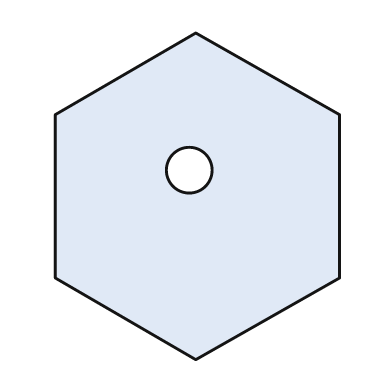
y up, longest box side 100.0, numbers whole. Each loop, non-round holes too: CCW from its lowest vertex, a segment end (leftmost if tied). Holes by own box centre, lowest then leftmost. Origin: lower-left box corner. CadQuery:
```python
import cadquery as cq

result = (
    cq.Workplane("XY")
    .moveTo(43.0, 0.0)
    .lineTo(87.0, 25.0)
    .lineTo(87.0, 75.0)
    .lineTo(43.0, 100.0)
    .lineTo(0.0, 75.0)
    .lineTo(0.0, 25.0)
    .close()
    .moveTo(41.0, 58.0)
    .circle(7.0)
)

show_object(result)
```